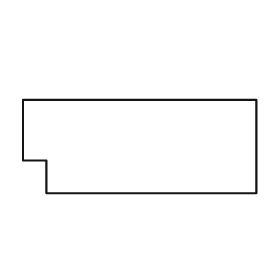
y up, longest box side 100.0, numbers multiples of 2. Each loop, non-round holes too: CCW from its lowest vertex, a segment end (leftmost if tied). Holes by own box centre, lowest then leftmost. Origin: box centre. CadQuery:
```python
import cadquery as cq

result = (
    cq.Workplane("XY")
    .moveTo(-40.0, -20.0)
    .lineTo(50.0, -20.0)
    .lineTo(50.0, 20.0)
    .lineTo(-50.0, 20.0)
    .lineTo(-50.0, -6.0)
    .lineTo(-40.0, -6.0)
    .close()
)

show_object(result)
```